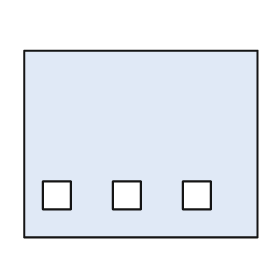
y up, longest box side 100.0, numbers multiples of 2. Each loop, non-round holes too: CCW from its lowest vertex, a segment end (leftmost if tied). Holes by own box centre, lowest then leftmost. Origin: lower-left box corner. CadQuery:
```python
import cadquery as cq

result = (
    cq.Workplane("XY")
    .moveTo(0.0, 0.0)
    .lineTo(100.0, 0.0)
    .lineTo(100.0, 80.0)
    .lineTo(0.0, 80.0)
    .close()
    .moveTo(8.0, 12.0)
    .lineTo(20.0, 12.0)
    .lineTo(20.0, 24.0)
    .lineTo(8.0, 24.0)
    .close()
    .moveTo(38.0, 12.0)
    .lineTo(50.0, 12.0)
    .lineTo(50.0, 24.0)
    .lineTo(38.0, 24.0)
    .close()
    .moveTo(68.0, 12.0)
    .lineTo(80.0, 12.0)
    .lineTo(80.0, 24.0)
    .lineTo(68.0, 24.0)
    .close()
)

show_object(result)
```